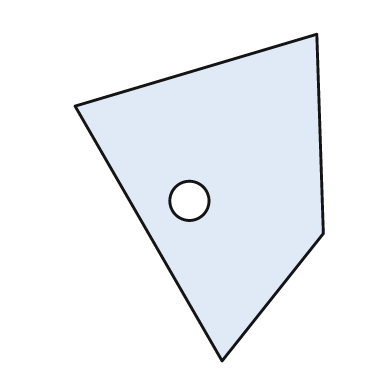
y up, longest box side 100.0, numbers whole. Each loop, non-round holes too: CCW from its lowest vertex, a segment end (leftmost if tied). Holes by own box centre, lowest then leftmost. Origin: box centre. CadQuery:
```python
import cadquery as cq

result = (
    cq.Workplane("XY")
    .moveTo(7.0, -50.0)
    .lineTo(38.0, -11.0)
    .lineTo(36.0, 50.0)
    .lineTo(-38.0, 28.0)
    .close()
    .moveTo(-3.0, -1.0)
    .circle(6.0)
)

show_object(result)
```